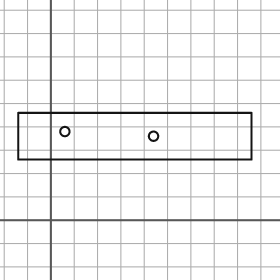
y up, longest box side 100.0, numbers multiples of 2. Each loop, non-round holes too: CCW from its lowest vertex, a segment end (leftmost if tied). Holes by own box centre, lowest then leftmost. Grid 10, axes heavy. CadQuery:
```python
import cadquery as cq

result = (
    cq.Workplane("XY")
    .moveTo(-14.0, 26.0)
    .lineTo(86.0, 26.0)
    .lineTo(86.0, 46.0)
    .lineTo(-14.0, 46.0)
    .close()
    .moveTo(44.0, 36.0)
    .circle(2.0)
    .moveTo(6.0, 38.0)
    .circle(2.0)
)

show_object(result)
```